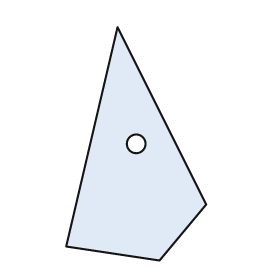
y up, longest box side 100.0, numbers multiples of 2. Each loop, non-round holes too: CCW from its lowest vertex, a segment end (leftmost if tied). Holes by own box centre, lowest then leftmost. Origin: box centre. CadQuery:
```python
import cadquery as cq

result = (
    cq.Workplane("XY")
    .moveTo(10.0, -50.0)
    .lineTo(30.0, -26.0)
    .lineTo(-8.0, 50.0)
    .lineTo(-30.0, -44.0)
    .close()
    .moveTo(0.0, 0.0)
    .circle(4.0)
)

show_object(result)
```